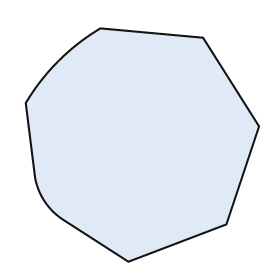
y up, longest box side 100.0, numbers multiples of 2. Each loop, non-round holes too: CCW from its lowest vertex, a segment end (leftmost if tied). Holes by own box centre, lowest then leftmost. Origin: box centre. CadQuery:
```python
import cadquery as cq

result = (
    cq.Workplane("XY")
    .moveTo(-6.0, -50.0)
    .lineTo(36.0, -34.0)
    .lineTo(50.0, 8.0)
    .lineTo(26.0, 46.0)
    .lineTo(-18.0, 50.0)
    .threePointArc((-36.0, 36.0), (-50.0, 18.0))
    .lineTo(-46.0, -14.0)
    .threePointArc((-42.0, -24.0), (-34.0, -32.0))
    .close()
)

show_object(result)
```